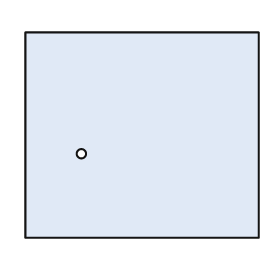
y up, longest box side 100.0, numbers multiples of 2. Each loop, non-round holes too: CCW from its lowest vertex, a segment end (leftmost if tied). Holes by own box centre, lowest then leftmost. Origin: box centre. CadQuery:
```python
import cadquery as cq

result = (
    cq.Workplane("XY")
    .moveTo(-50.0, -44.0)
    .lineTo(50.0, -44.0)
    .lineTo(50.0, 44.0)
    .lineTo(-50.0, 44.0)
    .close()
    .moveTo(-26.0, -8.0)
    .circle(2.0)
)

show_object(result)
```